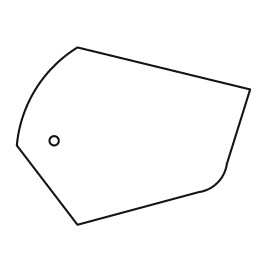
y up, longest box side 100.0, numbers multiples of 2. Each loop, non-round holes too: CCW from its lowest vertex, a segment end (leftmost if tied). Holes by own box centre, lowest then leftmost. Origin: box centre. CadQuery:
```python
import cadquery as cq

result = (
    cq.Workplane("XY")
    .moveTo(-24.0, -38.0)
    .lineTo(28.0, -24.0)
    .threePointArc((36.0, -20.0), (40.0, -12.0))
    .lineTo(50.0, 20.0)
    .lineTo(-24.0, 38.0)
    .threePointArc((-42.0, 20.0), (-50.0, -4.0))
    .close()
    .moveTo(-34.0, -2.0)
    .circle(2.0)
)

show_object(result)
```